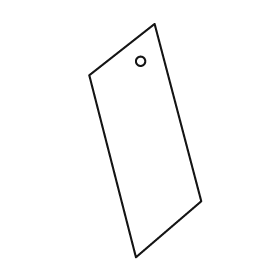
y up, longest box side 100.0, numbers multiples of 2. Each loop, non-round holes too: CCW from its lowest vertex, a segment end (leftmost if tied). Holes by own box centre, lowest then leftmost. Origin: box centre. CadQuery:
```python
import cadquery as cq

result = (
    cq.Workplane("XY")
    .moveTo(-4.0, -50.0)
    .lineTo(24.0, -26.0)
    .lineTo(4.0, 50.0)
    .lineTo(-24.0, 28.0)
    .close()
    .moveTo(-2.0, 34.0)
    .circle(2.0)
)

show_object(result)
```